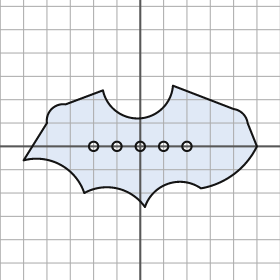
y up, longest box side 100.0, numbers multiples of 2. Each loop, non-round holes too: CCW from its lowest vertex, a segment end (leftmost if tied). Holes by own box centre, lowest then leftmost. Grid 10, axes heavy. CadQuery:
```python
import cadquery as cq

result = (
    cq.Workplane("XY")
    .moveTo(2.0, -26.0)
    .threePointArc((12.0, -16.0), (26.0, -18.0))
    .threePointArc((40.0, -12.0), (50.0, 0.0))
    .lineTo(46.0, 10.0)
    .threePointArc((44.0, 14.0), (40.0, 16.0))
    .lineTo(14.0, 26.0)
    .threePointArc((0.0, 12.0), (-16.0, 24.0))
    .lineTo(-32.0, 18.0)
    .threePointArc((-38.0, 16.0), (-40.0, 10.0))
    .lineTo(-50.0, -6.0)
    .threePointArc((-34.0, -8.0), (-24.0, -20.0))
    .threePointArc((-10.0, -18.0), (2.0, -26.0))
    .close()
    .moveTo(-20.0, 0.0)
    .circle(2.0)
    .moveTo(-10.0, 0.0)
    .circle(2.0)
    .moveTo(0.0, 0.0)
    .circle(2.0)
    .moveTo(10.0, 0.0)
    .circle(2.0)
    .moveTo(20.0, 0.0)
    .circle(2.0)
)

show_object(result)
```